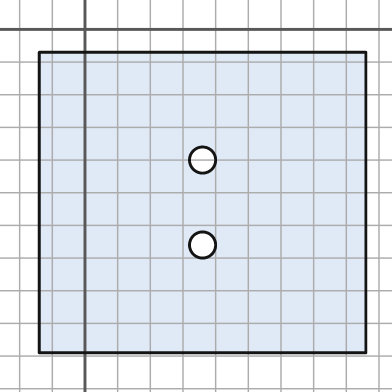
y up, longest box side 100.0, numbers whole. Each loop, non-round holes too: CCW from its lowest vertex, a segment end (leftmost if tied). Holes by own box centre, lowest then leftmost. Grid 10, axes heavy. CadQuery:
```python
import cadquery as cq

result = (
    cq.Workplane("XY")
    .moveTo(-14.0, -99.0)
    .lineTo(86.0, -99.0)
    .lineTo(86.0, -7.0)
    .lineTo(-14.0, -7.0)
    .close()
    .moveTo(36.0, -66.0)
    .circle(4.0)
    .moveTo(36.0, -40.0)
    .circle(4.0)
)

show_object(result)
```